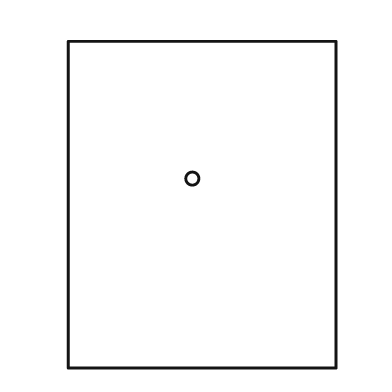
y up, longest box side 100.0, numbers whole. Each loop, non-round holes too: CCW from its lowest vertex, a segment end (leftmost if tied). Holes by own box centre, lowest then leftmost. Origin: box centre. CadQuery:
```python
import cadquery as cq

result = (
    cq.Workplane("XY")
    .moveTo(-41.0, -50.0)
    .lineTo(41.0, -50.0)
    .lineTo(41.0, 50.0)
    .lineTo(-41.0, 50.0)
    .close()
    .moveTo(-3.0, 8.0)
    .circle(2.0)
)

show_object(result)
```